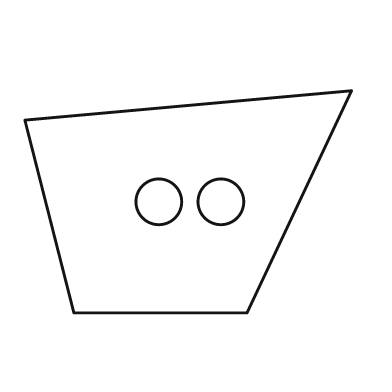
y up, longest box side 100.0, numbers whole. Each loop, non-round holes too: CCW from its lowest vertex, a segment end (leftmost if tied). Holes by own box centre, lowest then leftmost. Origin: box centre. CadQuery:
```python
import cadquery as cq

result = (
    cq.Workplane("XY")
    .moveTo(-35.0, -34.0)
    .lineTo(18.0, -34.0)
    .lineTo(50.0, 34.0)
    .lineTo(-50.0, 25.0)
    .close()
    .moveTo(-9.0, 0.0)
    .circle(7.0)
    .moveTo(10.0, 0.0)
    .circle(7.0)
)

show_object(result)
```